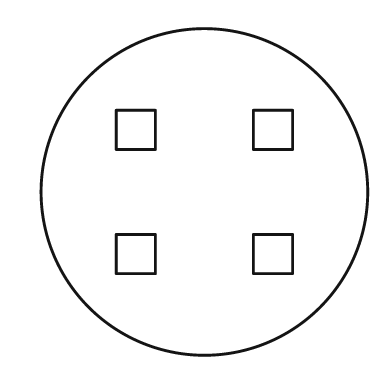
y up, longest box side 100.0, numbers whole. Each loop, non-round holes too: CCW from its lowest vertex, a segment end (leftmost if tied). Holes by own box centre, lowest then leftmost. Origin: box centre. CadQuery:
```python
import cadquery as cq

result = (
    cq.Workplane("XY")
    .moveTo(0.0, 0.0)
    .circle(50.0)
    .moveTo(-27.0, -25.0)
    .lineTo(-15.0, -25.0)
    .lineTo(-15.0, -13.0)
    .lineTo(-27.0, -13.0)
    .close()
    .moveTo(15.0, -25.0)
    .lineTo(27.0, -25.0)
    .lineTo(27.0, -13.0)
    .lineTo(15.0, -13.0)
    .close()
    .moveTo(-27.0, 13.0)
    .lineTo(-15.0, 13.0)
    .lineTo(-15.0, 25.0)
    .lineTo(-27.0, 25.0)
    .close()
    .moveTo(15.0, 13.0)
    .lineTo(27.0, 13.0)
    .lineTo(27.0, 25.0)
    .lineTo(15.0, 25.0)
    .close()
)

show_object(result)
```